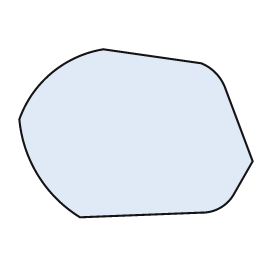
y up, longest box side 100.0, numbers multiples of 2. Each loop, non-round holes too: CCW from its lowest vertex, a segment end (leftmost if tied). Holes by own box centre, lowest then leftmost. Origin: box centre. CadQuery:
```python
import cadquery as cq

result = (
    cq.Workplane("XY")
    .moveTo(-24.0, -36.0)
    .lineTo(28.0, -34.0)
    .threePointArc((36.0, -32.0), (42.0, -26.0))
    .lineTo(50.0, -12.0)
    .lineTo(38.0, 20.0)
    .threePointArc((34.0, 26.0), (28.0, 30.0))
    .lineTo(-14.0, 36.0)
    .threePointArc((-36.0, 26.0), (-50.0, 6.0))
    .threePointArc((-42.0, -18.0), (-24.0, -36.0))
    .close()
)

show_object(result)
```